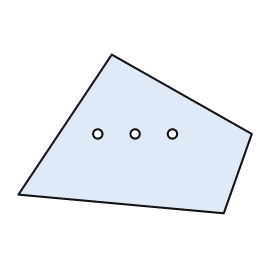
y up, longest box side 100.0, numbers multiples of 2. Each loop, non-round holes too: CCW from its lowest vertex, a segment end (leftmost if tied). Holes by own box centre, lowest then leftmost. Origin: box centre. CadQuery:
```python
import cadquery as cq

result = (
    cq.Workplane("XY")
    .moveTo(38.0, -34.0)
    .lineTo(50.0, 0.0)
    .lineTo(-10.0, 34.0)
    .lineTo(-50.0, -26.0)
    .close()
    .moveTo(-16.0, 0.0)
    .circle(2.0)
    .moveTo(0.0, 0.0)
    .circle(2.0)
    .moveTo(16.0, 0.0)
    .circle(2.0)
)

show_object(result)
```